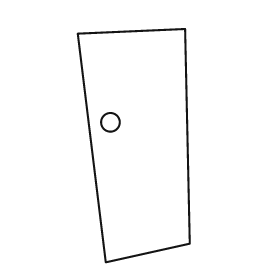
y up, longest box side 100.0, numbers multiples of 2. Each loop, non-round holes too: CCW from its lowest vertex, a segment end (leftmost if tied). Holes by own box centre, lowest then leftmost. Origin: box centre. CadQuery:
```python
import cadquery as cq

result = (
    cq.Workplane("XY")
    .moveTo(-12.0, -50.0)
    .lineTo(24.0, -42.0)
    .lineTo(22.0, 50.0)
    .lineTo(-24.0, 48.0)
    .close()
    .moveTo(-10.0, 10.0)
    .circle(4.0)
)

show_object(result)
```